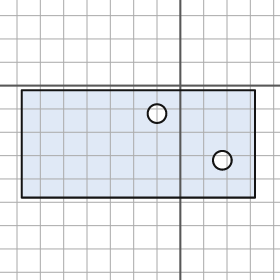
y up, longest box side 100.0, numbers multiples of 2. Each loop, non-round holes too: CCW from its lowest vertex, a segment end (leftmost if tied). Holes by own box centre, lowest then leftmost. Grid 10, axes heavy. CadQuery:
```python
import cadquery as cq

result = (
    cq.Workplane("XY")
    .moveTo(-68.0, -48.0)
    .lineTo(32.0, -48.0)
    .lineTo(32.0, -2.0)
    .lineTo(-68.0, -2.0)
    .close()
    .moveTo(18.0, -32.0)
    .circle(4.0)
    .moveTo(-10.0, -12.0)
    .circle(4.0)
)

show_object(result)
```